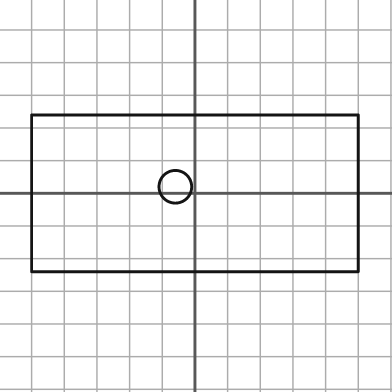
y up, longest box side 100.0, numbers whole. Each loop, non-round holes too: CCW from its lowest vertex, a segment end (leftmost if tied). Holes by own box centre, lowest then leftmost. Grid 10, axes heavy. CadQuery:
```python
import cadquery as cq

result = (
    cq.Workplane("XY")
    .moveTo(-50.0, -24.0)
    .lineTo(50.0, -24.0)
    .lineTo(50.0, 24.0)
    .lineTo(-50.0, 24.0)
    .close()
    .moveTo(-6.0, 2.0)
    .circle(5.0)
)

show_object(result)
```